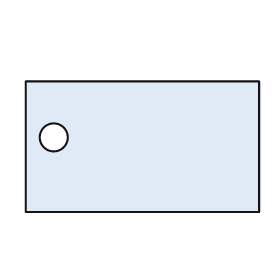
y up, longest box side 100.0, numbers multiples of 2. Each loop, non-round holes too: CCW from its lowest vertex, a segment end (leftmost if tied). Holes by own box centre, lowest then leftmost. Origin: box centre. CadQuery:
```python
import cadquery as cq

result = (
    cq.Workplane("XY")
    .moveTo(-50.0, -28.0)
    .lineTo(50.0, -28.0)
    .lineTo(50.0, 28.0)
    .lineTo(-50.0, 28.0)
    .close()
    .moveTo(-38.0, 4.0)
    .circle(6.0)
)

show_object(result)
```